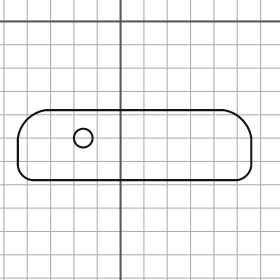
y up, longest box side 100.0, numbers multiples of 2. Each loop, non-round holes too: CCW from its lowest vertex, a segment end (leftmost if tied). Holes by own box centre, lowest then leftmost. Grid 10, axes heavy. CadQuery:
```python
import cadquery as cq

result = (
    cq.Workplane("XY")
    .moveTo(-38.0, -68.0)
    .lineTo(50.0, -68.0)
    .threePointArc((54.0, -66.0), (56.0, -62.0))
    .lineTo(56.0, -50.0)
    .threePointArc((52.0, -42.0), (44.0, -38.0))
    .lineTo(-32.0, -38.0)
    .threePointArc((-40.0, -42.0), (-44.0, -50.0))
    .lineTo(-44.0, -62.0)
    .threePointArc((-42.0, -66.0), (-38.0, -68.0))
    .close()
    .moveTo(-16.0, -50.0)
    .circle(4.0)
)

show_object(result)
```